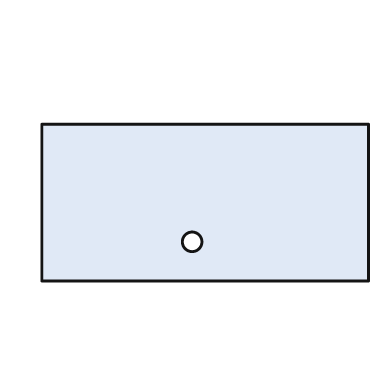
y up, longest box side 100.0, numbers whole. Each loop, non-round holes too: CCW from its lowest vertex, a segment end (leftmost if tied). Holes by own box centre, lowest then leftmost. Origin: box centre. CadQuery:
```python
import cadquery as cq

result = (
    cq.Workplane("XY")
    .moveTo(-50.0, -24.0)
    .lineTo(50.0, -24.0)
    .lineTo(50.0, 24.0)
    .lineTo(-50.0, 24.0)
    .close()
    .moveTo(-4.0, -12.0)
    .circle(3.0)
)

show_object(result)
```